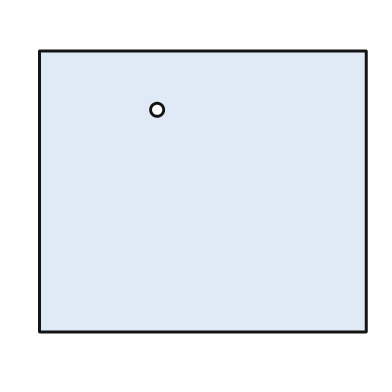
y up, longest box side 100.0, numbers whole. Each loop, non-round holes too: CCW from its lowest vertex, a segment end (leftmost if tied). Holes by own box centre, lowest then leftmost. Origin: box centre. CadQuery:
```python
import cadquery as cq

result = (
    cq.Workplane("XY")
    .moveTo(-50.0, -43.0)
    .lineTo(50.0, -43.0)
    .lineTo(50.0, 43.0)
    .lineTo(-50.0, 43.0)
    .close()
    .moveTo(-14.0, 25.0)
    .circle(2.0)
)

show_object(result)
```